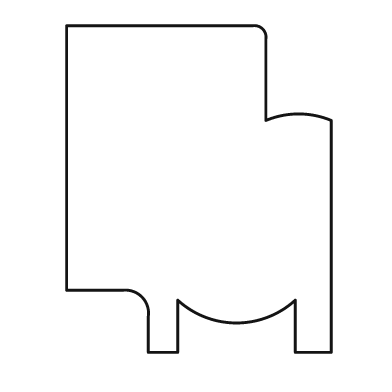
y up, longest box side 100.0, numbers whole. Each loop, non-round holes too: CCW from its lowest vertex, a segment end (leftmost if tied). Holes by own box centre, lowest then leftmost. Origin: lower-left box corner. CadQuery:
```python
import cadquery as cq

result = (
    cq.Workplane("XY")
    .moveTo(25.0, 0.0)
    .lineTo(34.0, 0.0)
    .lineTo(34.0, 16.0)
    .threePointArc((52.0, 9.0), (70.0, 16.0))
    .lineTo(70.0, 0.0)
    .lineTo(81.0, 0.0)
    .lineTo(81.0, 71.0)
    .threePointArc((71.0, 73.0), (61.0, 71.0))
    .lineTo(61.0, 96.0)
    .threePointArc((60.0, 99.0), (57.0, 100.0))
    .lineTo(0.0, 100.0)
    .lineTo(0.0, 19.0)
    .lineTo(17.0, 19.0)
    .threePointArc((23.0, 17.0), (25.0, 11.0))
    .close()
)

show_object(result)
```